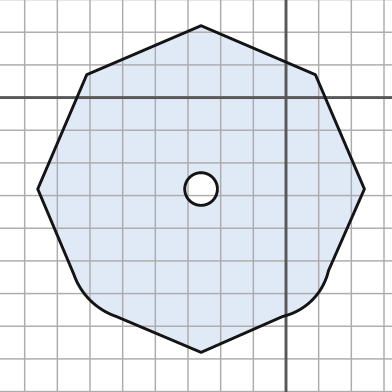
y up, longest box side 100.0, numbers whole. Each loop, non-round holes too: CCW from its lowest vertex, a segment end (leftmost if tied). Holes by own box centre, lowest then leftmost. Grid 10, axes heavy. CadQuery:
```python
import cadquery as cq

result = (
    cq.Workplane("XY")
    .moveTo(-26.0, -78.0)
    .lineTo(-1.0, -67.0)
    .threePointArc((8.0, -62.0), (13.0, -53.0))
    .lineTo(24.0, -28.0)
    .lineTo(9.0, 7.0)
    .lineTo(-26.0, 22.0)
    .lineTo(-61.0, 7.0)
    .lineTo(-76.0, -28.0)
    .lineTo(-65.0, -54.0)
    .threePointArc((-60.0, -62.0), (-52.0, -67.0))
    .close()
    .moveTo(-26.0, -28.0)
    .circle(5.0)
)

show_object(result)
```